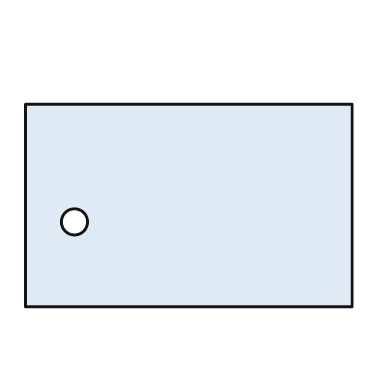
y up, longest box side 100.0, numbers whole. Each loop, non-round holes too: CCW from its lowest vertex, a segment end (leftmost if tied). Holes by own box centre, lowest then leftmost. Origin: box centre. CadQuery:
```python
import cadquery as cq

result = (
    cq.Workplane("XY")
    .moveTo(-50.0, -31.0)
    .lineTo(50.0, -31.0)
    .lineTo(50.0, 31.0)
    .lineTo(-50.0, 31.0)
    .close()
    .moveTo(-35.0, -5.0)
    .circle(4.0)
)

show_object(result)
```